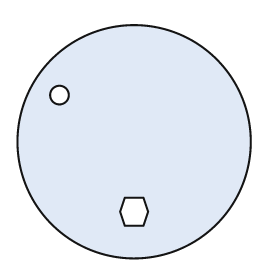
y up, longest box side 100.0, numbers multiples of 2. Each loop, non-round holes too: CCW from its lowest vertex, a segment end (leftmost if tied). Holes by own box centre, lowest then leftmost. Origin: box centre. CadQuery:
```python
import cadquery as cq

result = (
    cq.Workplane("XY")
    .moveTo(0.0, 0.0)
    .circle(50.0)
    .moveTo(-4.0, -36.0)
    .lineTo(4.0, -36.0)
    .lineTo(6.0, -30.0)
    .lineTo(4.0, -24.0)
    .lineTo(-4.0, -24.0)
    .lineTo(-6.0, -30.0)
    .close()
    .moveTo(-32.0, 20.0)
    .circle(4.0)
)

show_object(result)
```